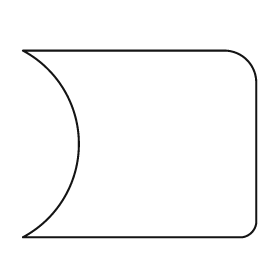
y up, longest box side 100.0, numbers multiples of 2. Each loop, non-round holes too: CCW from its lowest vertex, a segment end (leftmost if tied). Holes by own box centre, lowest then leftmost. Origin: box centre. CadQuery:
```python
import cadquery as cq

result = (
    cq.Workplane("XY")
    .moveTo(-50.0, -40.0)
    .lineTo(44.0, -40.0)
    .threePointArc((48.0, -38.0), (50.0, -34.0))
    .lineTo(50.0, 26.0)
    .threePointArc((46.0, 36.0), (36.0, 40.0))
    .lineTo(-50.0, 40.0)
    .threePointArc((-26.0, 0.0), (-50.0, -40.0))
    .close()
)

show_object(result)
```